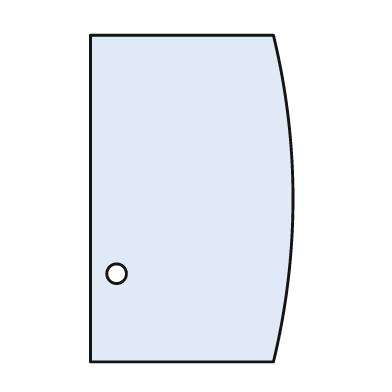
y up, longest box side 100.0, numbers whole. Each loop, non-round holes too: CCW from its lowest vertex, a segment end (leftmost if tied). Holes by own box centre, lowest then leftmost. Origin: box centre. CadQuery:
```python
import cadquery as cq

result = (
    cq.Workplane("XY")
    .moveTo(-31.0, -50.0)
    .lineTo(25.0, -50.0)
    .threePointArc((31.0, 0.0), (25.0, 50.0))
    .lineTo(-31.0, 50.0)
    .close()
    .moveTo(-23.0, -23.0)
    .circle(3.0)
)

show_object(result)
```